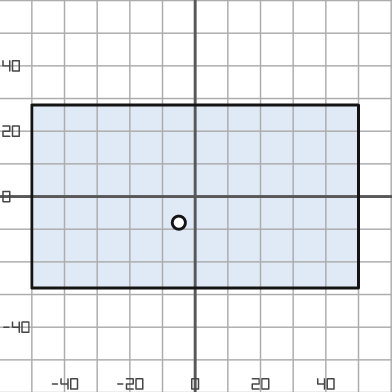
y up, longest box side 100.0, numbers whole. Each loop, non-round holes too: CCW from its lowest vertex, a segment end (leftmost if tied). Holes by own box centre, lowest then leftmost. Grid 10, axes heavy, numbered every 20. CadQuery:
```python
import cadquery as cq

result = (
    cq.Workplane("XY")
    .moveTo(-50.0, -28.0)
    .lineTo(50.0, -28.0)
    .lineTo(50.0, 28.0)
    .lineTo(-50.0, 28.0)
    .close()
    .moveTo(-5.0, -8.0)
    .circle(2.0)
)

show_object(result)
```